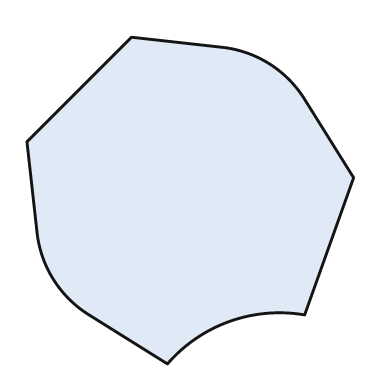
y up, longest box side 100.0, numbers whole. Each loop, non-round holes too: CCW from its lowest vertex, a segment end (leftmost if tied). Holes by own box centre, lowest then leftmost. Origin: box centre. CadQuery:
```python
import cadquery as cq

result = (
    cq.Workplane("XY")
    .moveTo(-7.0, -50.0)
    .threePointArc((12.0, -37.0), (35.0, -35.0))
    .lineTo(50.0, 7.0)
    .lineTo(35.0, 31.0)
    .threePointArc((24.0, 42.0), (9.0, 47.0))
    .lineTo(-18.0, 50.0)
    .lineTo(-50.0, 18.0)
    .lineTo(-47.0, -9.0)
    .threePointArc((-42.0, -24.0), (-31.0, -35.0))
    .close()
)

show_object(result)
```